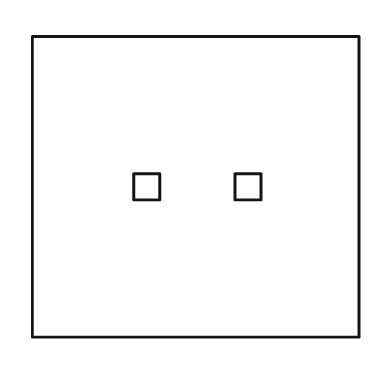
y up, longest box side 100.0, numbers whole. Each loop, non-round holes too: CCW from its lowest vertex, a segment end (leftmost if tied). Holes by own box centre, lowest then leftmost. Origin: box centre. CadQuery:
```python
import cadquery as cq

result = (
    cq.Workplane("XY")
    .moveTo(-50.0, -46.0)
    .lineTo(50.0, -46.0)
    .lineTo(50.0, 46.0)
    .lineTo(-50.0, 46.0)
    .close()
    .moveTo(-19.0, -4.0)
    .lineTo(-11.0, -4.0)
    .lineTo(-11.0, 4.0)
    .lineTo(-19.0, 4.0)
    .close()
    .moveTo(12.0, -4.0)
    .lineTo(20.0, -4.0)
    .lineTo(20.0, 4.0)
    .lineTo(12.0, 4.0)
    .close()
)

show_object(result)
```